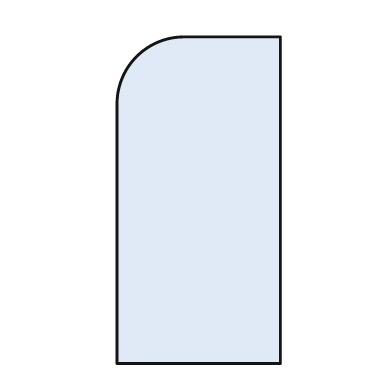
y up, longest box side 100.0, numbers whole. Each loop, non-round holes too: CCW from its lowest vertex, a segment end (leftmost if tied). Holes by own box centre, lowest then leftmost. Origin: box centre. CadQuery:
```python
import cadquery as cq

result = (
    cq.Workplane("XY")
    .moveTo(-25.0, -50.0)
    .lineTo(25.0, -50.0)
    .lineTo(25.0, 50.0)
    .lineTo(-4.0, 50.0)
    .threePointArc((-19.0, 44.0), (-25.0, 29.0))
    .close()
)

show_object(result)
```